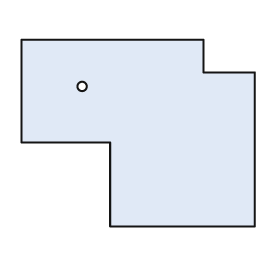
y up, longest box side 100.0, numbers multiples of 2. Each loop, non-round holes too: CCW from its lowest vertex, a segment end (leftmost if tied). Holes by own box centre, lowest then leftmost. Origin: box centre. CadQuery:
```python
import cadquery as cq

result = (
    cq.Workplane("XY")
    .moveTo(-12.0, -40.0)
    .lineTo(50.0, -40.0)
    .lineTo(50.0, 26.0)
    .lineTo(28.0, 26.0)
    .lineTo(28.0, 40.0)
    .lineTo(-50.0, 40.0)
    .lineTo(-50.0, -4.0)
    .lineTo(-12.0, -4.0)
    .close()
    .moveTo(-24.0, 20.0)
    .circle(2.0)
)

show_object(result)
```